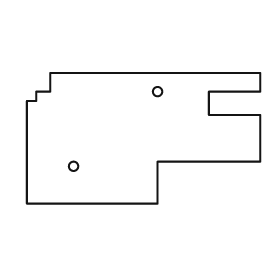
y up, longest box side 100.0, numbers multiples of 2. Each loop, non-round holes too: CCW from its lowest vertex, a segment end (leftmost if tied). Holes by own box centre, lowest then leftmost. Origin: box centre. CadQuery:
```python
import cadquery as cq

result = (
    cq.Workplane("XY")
    .moveTo(-50.0, -28.0)
    .lineTo(6.0, -28.0)
    .lineTo(6.0, -10.0)
    .lineTo(50.0, -10.0)
    .lineTo(50.0, 10.0)
    .lineTo(28.0, 10.0)
    .lineTo(28.0, 20.0)
    .lineTo(50.0, 20.0)
    .lineTo(50.0, 28.0)
    .lineTo(-40.0, 28.0)
    .lineTo(-40.0, 20.0)
    .lineTo(-46.0, 20.0)
    .lineTo(-46.0, 16.0)
    .lineTo(-50.0, 16.0)
    .close()
    .moveTo(-30.0, -12.0)
    .circle(2.0)
    .moveTo(6.0, 20.0)
    .circle(2.0)
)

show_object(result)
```